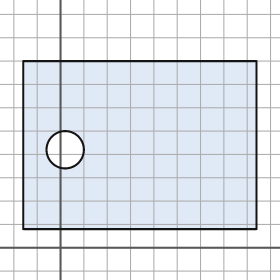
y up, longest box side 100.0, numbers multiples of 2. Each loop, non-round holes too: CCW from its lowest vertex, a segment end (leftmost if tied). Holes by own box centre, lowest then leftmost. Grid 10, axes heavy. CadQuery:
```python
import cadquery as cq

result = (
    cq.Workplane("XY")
    .moveTo(-16.0, 8.0)
    .lineTo(84.0, 8.0)
    .lineTo(84.0, 80.0)
    .lineTo(-16.0, 80.0)
    .close()
    .moveTo(2.0, 42.0)
    .circle(8.0)
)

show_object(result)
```